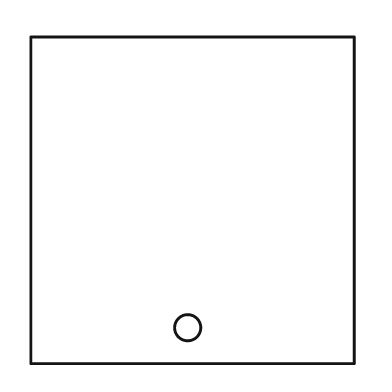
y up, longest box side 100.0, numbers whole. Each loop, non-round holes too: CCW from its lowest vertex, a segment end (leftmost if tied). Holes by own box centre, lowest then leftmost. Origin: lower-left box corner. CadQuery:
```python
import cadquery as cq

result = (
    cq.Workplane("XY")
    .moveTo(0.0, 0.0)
    .lineTo(99.0, 0.0)
    .lineTo(99.0, 100.0)
    .lineTo(0.0, 100.0)
    .close()
    .moveTo(48.0, 11.0)
    .circle(4.0)
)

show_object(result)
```